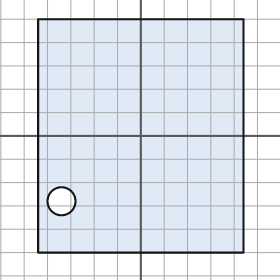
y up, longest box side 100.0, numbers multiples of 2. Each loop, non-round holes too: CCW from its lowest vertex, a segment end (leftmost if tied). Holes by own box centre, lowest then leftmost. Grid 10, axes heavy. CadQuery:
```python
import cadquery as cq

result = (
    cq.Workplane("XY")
    .moveTo(-44.0, -50.0)
    .lineTo(44.0, -50.0)
    .lineTo(44.0, 50.0)
    .lineTo(-44.0, 50.0)
    .close()
    .moveTo(-34.0, -28.0)
    .circle(6.0)
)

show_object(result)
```